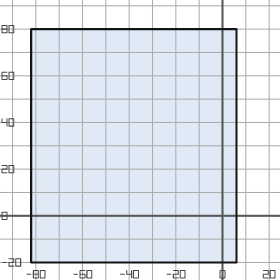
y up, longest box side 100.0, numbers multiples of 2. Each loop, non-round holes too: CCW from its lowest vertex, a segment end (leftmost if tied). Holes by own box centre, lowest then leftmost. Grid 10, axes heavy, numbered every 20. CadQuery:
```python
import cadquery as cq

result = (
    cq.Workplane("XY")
    .moveTo(-82.0, -20.0)
    .lineTo(6.0, -20.0)
    .lineTo(6.0, 80.0)
    .lineTo(-82.0, 80.0)
    .close()
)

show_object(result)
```